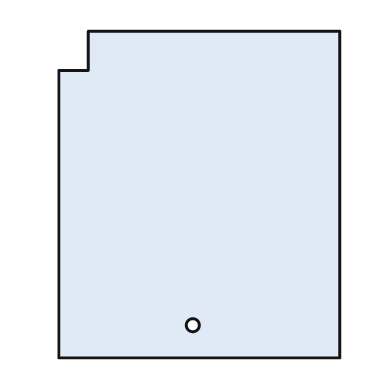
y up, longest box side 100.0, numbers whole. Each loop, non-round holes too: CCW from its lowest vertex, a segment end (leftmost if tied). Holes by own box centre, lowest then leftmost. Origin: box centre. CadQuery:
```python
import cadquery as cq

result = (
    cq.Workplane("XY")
    .moveTo(-43.0, -50.0)
    .lineTo(43.0, -50.0)
    .lineTo(43.0, 50.0)
    .lineTo(-34.0, 50.0)
    .lineTo(-34.0, 38.0)
    .lineTo(-43.0, 38.0)
    .close()
    .moveTo(-2.0, -40.0)
    .circle(2.0)
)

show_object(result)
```